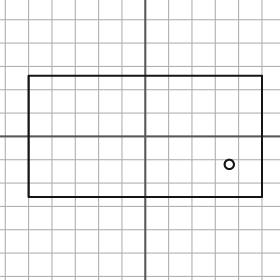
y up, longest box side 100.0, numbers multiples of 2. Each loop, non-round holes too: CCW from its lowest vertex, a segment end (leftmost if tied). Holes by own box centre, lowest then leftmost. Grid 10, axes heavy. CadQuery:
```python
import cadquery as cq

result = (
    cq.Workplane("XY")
    .moveTo(-50.0, -26.0)
    .lineTo(50.0, -26.0)
    .lineTo(50.0, 26.0)
    .lineTo(-50.0, 26.0)
    .close()
    .moveTo(36.0, -12.0)
    .circle(2.0)
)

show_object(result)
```